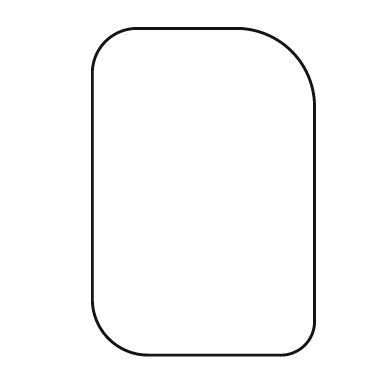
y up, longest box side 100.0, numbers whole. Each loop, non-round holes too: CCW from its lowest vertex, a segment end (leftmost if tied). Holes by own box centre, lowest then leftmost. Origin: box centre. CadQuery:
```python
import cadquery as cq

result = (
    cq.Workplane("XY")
    .moveTo(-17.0, -50.0)
    .lineTo(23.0, -50.0)
    .threePointArc((31.0, -47.0), (34.0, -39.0))
    .lineTo(34.0, 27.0)
    .threePointArc((27.0, 43.0), (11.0, 50.0))
    .lineTo(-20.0, 50.0)
    .threePointArc((-30.0, 46.0), (-34.0, 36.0))
    .lineTo(-34.0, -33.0)
    .threePointArc((-29.0, -45.0), (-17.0, -50.0))
    .close()
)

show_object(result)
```